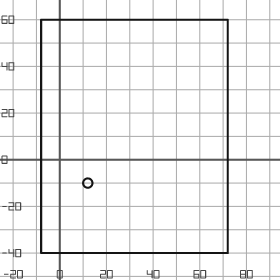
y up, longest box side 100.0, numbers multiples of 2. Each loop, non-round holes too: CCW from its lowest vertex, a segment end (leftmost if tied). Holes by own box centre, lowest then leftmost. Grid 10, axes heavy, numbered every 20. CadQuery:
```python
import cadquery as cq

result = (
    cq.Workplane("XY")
    .moveTo(-8.0, -40.0)
    .lineTo(72.0, -40.0)
    .lineTo(72.0, 60.0)
    .lineTo(-8.0, 60.0)
    .close()
    .moveTo(12.0, -10.0)
    .circle(2.0)
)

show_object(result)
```